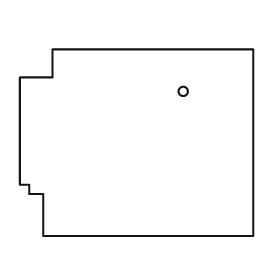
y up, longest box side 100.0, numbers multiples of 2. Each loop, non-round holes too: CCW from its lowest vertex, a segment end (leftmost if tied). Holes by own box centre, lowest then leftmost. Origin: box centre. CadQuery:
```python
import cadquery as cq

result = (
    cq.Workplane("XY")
    .moveTo(-40.0, -40.0)
    .lineTo(50.0, -40.0)
    .lineTo(50.0, 40.0)
    .lineTo(-36.0, 40.0)
    .lineTo(-36.0, 28.0)
    .lineTo(-50.0, 28.0)
    .lineTo(-50.0, -18.0)
    .lineTo(-46.0, -18.0)
    .lineTo(-46.0, -22.0)
    .lineTo(-40.0, -22.0)
    .close()
    .moveTo(20.0, 22.0)
    .circle(2.0)
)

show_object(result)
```